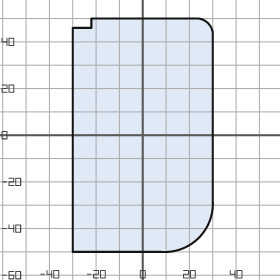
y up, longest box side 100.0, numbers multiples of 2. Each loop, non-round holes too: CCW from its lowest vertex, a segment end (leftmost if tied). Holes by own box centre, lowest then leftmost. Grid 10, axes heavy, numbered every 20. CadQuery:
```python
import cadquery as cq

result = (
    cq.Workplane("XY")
    .moveTo(-30.0, -50.0)
    .lineTo(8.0, -50.0)
    .threePointArc((24.0, -44.0), (30.0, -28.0))
    .lineTo(30.0, 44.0)
    .threePointArc((28.0, 48.0), (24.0, 50.0))
    .lineTo(-22.0, 50.0)
    .lineTo(-22.0, 46.0)
    .lineTo(-30.0, 46.0)
    .close()
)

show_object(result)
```